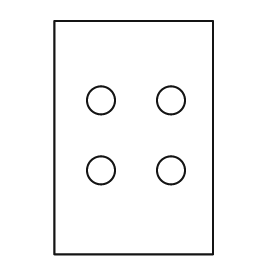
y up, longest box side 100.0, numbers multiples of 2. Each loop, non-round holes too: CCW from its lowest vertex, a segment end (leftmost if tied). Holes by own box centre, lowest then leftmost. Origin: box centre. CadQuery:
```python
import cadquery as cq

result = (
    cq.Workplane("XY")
    .moveTo(-34.0, -50.0)
    .lineTo(34.0, -50.0)
    .lineTo(34.0, 50.0)
    .lineTo(-34.0, 50.0)
    .close()
    .moveTo(-14.0, -14.0)
    .circle(6.0)
    .moveTo(16.0, -14.0)
    .circle(6.0)
    .moveTo(-14.0, 16.0)
    .circle(6.0)
    .moveTo(16.0, 16.0)
    .circle(6.0)
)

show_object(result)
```